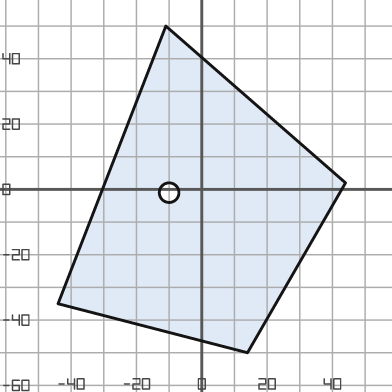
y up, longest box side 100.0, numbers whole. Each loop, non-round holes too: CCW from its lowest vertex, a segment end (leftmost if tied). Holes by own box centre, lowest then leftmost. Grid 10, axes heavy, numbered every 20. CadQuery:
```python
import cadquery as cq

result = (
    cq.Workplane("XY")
    .moveTo(14.0, -50.0)
    .lineTo(44.0, 2.0)
    .lineTo(-11.0, 50.0)
    .lineTo(-44.0, -35.0)
    .close()
    .moveTo(-10.0, -1.0)
    .circle(3.0)
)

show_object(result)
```